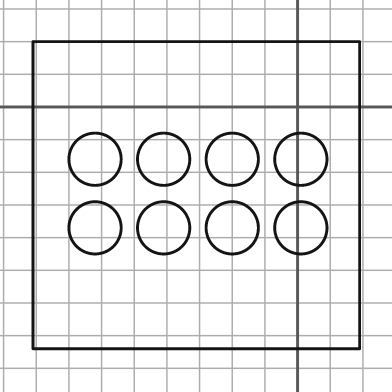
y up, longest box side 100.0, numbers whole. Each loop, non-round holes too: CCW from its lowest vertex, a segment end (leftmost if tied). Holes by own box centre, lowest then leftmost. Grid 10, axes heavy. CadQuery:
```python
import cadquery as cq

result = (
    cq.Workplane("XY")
    .moveTo(-81.0, -74.0)
    .lineTo(19.0, -74.0)
    .lineTo(19.0, 20.0)
    .lineTo(-81.0, 20.0)
    .close()
    .moveTo(-62.0, -37.0)
    .circle(8.0)
    .moveTo(-41.0, -37.0)
    .circle(8.0)
    .moveTo(-20.0, -37.0)
    .circle(8.0)
    .moveTo(1.0, -37.0)
    .circle(8.0)
    .moveTo(-62.0, -16.0)
    .circle(8.0)
    .moveTo(-41.0, -16.0)
    .circle(8.0)
    .moveTo(-20.0, -16.0)
    .circle(8.0)
    .moveTo(1.0, -16.0)
    .circle(8.0)
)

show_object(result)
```